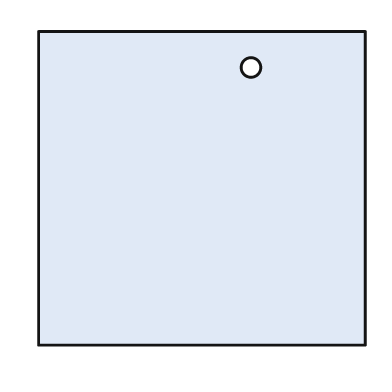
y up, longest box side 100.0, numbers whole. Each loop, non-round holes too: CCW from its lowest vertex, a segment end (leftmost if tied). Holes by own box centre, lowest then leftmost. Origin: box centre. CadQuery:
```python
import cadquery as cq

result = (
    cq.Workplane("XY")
    .moveTo(-50.0, -48.0)
    .lineTo(50.0, -48.0)
    .lineTo(50.0, 48.0)
    .lineTo(-50.0, 48.0)
    .close()
    .moveTo(15.0, 37.0)
    .circle(3.0)
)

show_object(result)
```